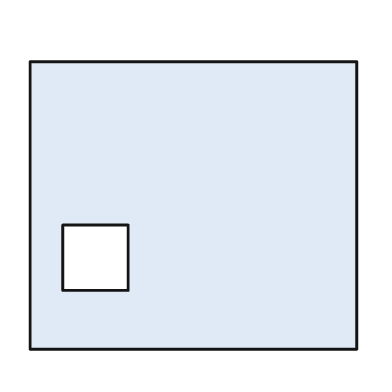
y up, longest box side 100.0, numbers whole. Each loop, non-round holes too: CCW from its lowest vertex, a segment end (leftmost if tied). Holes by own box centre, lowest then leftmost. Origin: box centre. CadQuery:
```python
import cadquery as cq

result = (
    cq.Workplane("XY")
    .moveTo(-50.0, -44.0)
    .lineTo(50.0, -44.0)
    .lineTo(50.0, 44.0)
    .lineTo(-50.0, 44.0)
    .close()
    .moveTo(-40.0, -26.0)
    .lineTo(-20.0, -26.0)
    .lineTo(-20.0, -6.0)
    .lineTo(-40.0, -6.0)
    .close()
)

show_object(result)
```